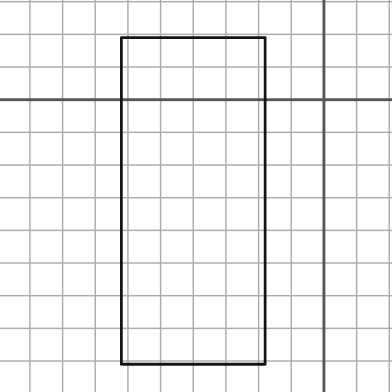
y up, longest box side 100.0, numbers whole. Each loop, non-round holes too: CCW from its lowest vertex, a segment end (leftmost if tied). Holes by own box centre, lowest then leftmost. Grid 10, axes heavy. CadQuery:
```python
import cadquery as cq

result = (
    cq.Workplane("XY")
    .moveTo(-62.0, -81.0)
    .lineTo(-18.0, -81.0)
    .lineTo(-18.0, 19.0)
    .lineTo(-62.0, 19.0)
    .close()
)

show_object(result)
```